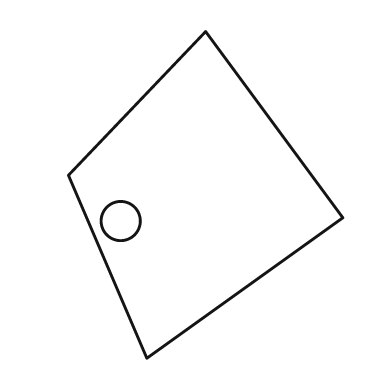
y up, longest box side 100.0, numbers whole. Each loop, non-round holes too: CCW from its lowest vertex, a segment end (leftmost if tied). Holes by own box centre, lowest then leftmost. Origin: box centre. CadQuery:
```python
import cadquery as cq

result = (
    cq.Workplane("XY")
    .moveTo(-18.0, -50.0)
    .lineTo(42.0, -7.0)
    .lineTo(0.0, 50.0)
    .lineTo(-42.0, 6.0)
    .close()
    .moveTo(-26.0, -8.0)
    .circle(6.0)
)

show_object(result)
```